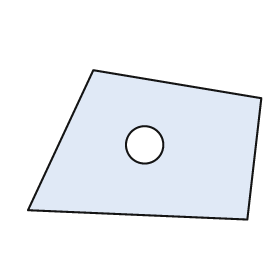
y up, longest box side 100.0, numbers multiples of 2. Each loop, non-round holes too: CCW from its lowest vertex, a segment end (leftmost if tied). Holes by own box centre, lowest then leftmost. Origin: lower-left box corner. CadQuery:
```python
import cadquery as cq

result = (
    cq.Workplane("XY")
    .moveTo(94.0, 0.0)
    .lineTo(100.0, 52.0)
    .lineTo(28.0, 64.0)
    .lineTo(0.0, 4.0)
    .close()
    .moveTo(50.0, 32.0)
    .circle(8.0)
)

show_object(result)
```